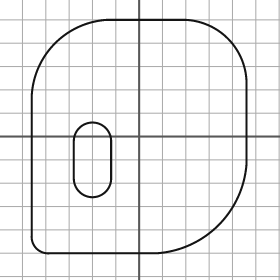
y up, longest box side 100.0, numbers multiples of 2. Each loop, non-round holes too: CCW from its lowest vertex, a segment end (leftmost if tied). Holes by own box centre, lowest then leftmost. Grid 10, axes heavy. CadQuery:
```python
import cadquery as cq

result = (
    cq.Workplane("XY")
    .moveTo(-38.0, -50.0)
    .lineTo(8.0, -50.0)
    .threePointArc((34.0, -38.0), (46.0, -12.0))
    .lineTo(46.0, 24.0)
    .threePointArc((38.0, 42.0), (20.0, 50.0))
    .lineTo(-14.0, 50.0)
    .threePointArc((-36.0, 40.0), (-46.0, 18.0))
    .lineTo(-46.0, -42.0)
    .threePointArc((-44.0, -48.0), (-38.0, -50.0))
    .close()
    .moveTo(-28.0, -18.0)
    .threePointArc((-20.0, -26.0), (-12.0, -18.0))
    .lineTo(-12.0, -2.0)
    .threePointArc((-20.0, 6.0), (-28.0, -2.0))
    .close()
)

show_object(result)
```